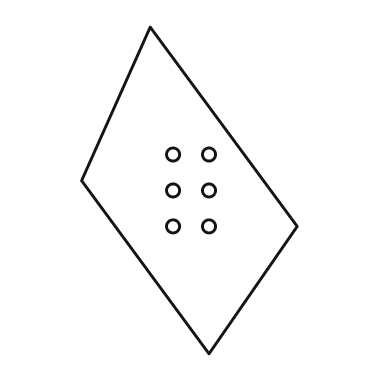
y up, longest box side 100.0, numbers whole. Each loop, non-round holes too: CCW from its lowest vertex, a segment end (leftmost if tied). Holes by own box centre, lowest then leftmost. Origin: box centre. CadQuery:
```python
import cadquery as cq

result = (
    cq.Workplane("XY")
    .moveTo(6.0, -50.0)
    .lineTo(33.0, -11.0)
    .lineTo(-12.0, 50.0)
    .lineTo(-33.0, 3.0)
    .close()
    .moveTo(-5.0, -11.0)
    .circle(2.0)
    .moveTo(6.0, -11.0)
    .circle(2.0)
    .moveTo(-5.0, 0.0)
    .circle(2.0)
    .moveTo(6.0, 0.0)
    .circle(2.0)
    .moveTo(-5.0, 11.0)
    .circle(2.0)
    .moveTo(6.0, 11.0)
    .circle(2.0)
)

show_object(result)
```